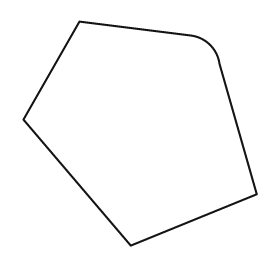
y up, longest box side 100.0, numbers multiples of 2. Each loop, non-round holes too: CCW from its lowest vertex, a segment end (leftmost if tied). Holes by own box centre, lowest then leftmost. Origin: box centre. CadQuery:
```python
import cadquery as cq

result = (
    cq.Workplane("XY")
    .moveTo(-4.0, -48.0)
    .lineTo(50.0, -26.0)
    .lineTo(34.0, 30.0)
    .threePointArc((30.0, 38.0), (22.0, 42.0))
    .lineTo(-26.0, 48.0)
    .lineTo(-50.0, 6.0)
    .close()
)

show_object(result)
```